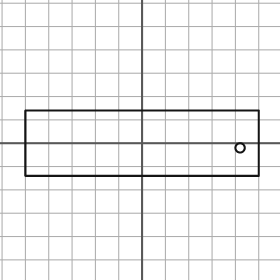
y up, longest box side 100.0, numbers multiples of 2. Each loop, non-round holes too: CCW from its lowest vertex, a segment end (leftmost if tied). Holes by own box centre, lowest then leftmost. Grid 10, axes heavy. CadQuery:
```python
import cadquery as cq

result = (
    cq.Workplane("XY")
    .moveTo(-50.0, -14.0)
    .lineTo(50.0, -14.0)
    .lineTo(50.0, 14.0)
    .lineTo(-50.0, 14.0)
    .close()
    .moveTo(42.0, -2.0)
    .circle(2.0)
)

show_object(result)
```